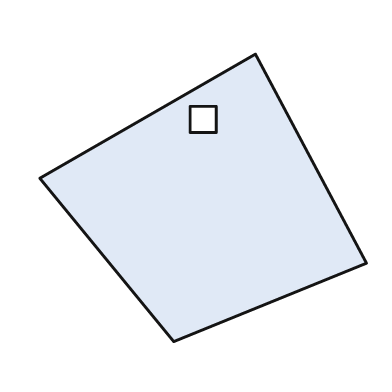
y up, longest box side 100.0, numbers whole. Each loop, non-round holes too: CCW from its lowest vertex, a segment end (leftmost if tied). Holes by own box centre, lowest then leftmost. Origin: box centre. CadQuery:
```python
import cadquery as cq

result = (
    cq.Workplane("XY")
    .moveTo(-9.0, -44.0)
    .lineTo(50.0, -20.0)
    .lineTo(16.0, 44.0)
    .lineTo(-50.0, 6.0)
    .close()
    .moveTo(-4.0, 20.0)
    .lineTo(4.0, 20.0)
    .lineTo(4.0, 28.0)
    .lineTo(-4.0, 28.0)
    .close()
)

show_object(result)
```